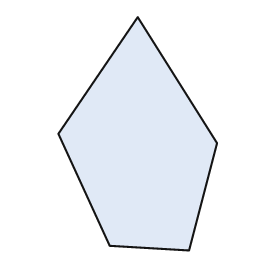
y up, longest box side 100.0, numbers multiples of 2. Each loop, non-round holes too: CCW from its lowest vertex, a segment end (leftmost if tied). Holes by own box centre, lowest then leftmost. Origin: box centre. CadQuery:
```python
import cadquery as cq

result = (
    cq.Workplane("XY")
    .moveTo(22.0, -50.0)
    .lineTo(34.0, -4.0)
    .lineTo(0.0, 50.0)
    .lineTo(-34.0, 0.0)
    .lineTo(-12.0, -48.0)
    .close()
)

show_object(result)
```